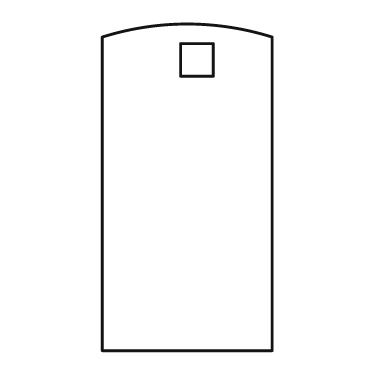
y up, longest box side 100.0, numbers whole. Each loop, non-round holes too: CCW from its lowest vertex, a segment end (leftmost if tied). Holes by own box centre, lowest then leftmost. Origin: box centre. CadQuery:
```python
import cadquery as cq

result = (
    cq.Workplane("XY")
    .moveTo(-26.0, -50.0)
    .lineTo(26.0, -50.0)
    .lineTo(26.0, 46.0)
    .threePointArc((0.0, 50.0), (-26.0, 46.0))
    .close()
    .moveTo(-2.0, 34.0)
    .lineTo(8.0, 34.0)
    .lineTo(8.0, 44.0)
    .lineTo(-2.0, 44.0)
    .close()
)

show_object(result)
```